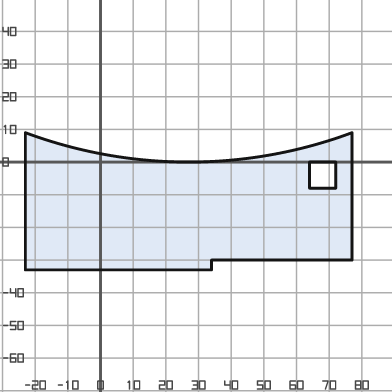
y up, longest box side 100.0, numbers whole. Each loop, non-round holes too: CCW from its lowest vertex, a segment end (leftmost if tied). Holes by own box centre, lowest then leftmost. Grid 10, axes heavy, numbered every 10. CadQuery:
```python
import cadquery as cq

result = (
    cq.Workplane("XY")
    .moveTo(-23.0, -33.0)
    .lineTo(34.0, -33.0)
    .lineTo(34.0, -30.0)
    .lineTo(77.0, -30.0)
    .lineTo(77.0, 9.0)
    .threePointArc((27.0, 0.0), (-23.0, 9.0))
    .close()
    .moveTo(64.0, -8.0)
    .lineTo(72.0, -8.0)
    .lineTo(72.0, 0.0)
    .lineTo(64.0, 0.0)
    .close()
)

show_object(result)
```